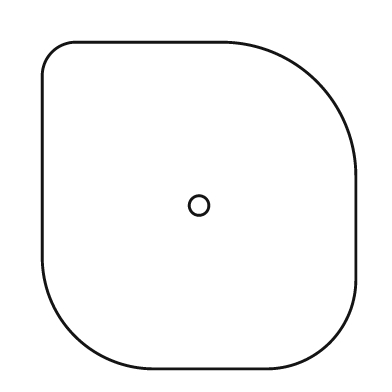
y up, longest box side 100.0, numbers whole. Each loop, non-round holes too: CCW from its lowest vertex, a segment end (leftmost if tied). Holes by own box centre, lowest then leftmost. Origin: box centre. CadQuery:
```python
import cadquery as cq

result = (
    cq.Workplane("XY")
    .moveTo(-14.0, -50.0)
    .lineTo(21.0, -50.0)
    .threePointArc((40.0, -42.0), (48.0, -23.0))
    .lineTo(48.0, 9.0)
    .threePointArc((36.0, 38.0), (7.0, 50.0))
    .lineTo(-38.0, 50.0)
    .threePointArc((-45.0, 47.0), (-48.0, 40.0))
    .lineTo(-48.0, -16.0)
    .threePointArc((-38.0, -40.0), (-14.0, -50.0))
    .close()
    .moveTo(0.0, 0.0)
    .circle(3.0)
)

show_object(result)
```